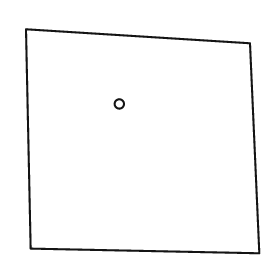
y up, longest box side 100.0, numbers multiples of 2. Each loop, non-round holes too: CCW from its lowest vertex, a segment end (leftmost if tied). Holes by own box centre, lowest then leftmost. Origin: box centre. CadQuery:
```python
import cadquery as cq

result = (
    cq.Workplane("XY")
    .moveTo(50.0, -48.0)
    .lineTo(46.0, 42.0)
    .lineTo(-50.0, 48.0)
    .lineTo(-48.0, -46.0)
    .close()
    .moveTo(-10.0, 16.0)
    .circle(2.0)
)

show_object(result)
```